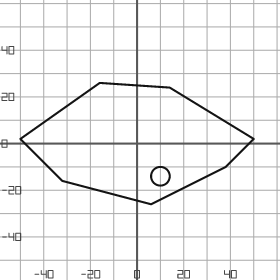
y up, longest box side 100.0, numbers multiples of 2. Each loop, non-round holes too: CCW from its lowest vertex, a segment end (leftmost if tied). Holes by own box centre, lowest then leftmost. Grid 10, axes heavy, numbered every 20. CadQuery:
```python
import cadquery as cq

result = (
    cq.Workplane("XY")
    .moveTo(6.0, -26.0)
    .lineTo(38.0, -10.0)
    .lineTo(50.0, 2.0)
    .lineTo(14.0, 24.0)
    .lineTo(-16.0, 26.0)
    .lineTo(-50.0, 2.0)
    .lineTo(-32.0, -16.0)
    .close()
    .moveTo(10.0, -14.0)
    .circle(4.0)
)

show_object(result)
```